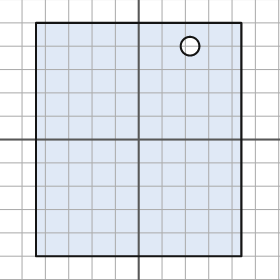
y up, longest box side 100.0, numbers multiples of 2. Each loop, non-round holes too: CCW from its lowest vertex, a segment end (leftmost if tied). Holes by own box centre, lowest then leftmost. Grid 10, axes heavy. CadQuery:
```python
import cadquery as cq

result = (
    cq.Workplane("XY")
    .moveTo(-44.0, -50.0)
    .lineTo(44.0, -50.0)
    .lineTo(44.0, 50.0)
    .lineTo(-44.0, 50.0)
    .close()
    .moveTo(22.0, 40.0)
    .circle(4.0)
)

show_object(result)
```